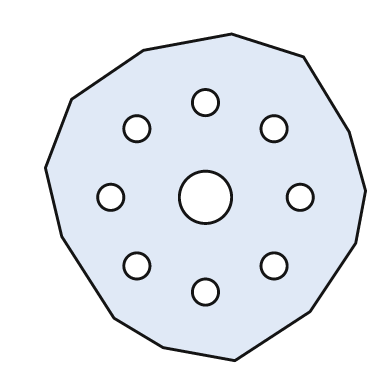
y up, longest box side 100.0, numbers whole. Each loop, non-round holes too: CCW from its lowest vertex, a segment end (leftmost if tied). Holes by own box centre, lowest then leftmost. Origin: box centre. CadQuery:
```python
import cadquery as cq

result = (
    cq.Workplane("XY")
    .moveTo(9.0, -50.0)
    .lineTo(32.0, -35.0)
    .lineTo(46.0, -14.0)
    .lineTo(49.0, 2.0)
    .lineTo(44.0, 20.0)
    .lineTo(30.0, 43.0)
    .lineTo(8.0, 50.0)
    .lineTo(-19.0, 45.0)
    .lineTo(-41.0, 30.0)
    .lineTo(-49.0, 9.0)
    .lineTo(-44.0, -12.0)
    .lineTo(-28.0, -37.0)
    .lineTo(-13.0, -46.0)
    .close()
    .moveTo(0.0, -29.0)
    .circle(4.0)
    .moveTo(-21.0, -21.0)
    .circle(4.0)
    .moveTo(21.0, -21.0)
    .circle(4.0)
    .moveTo(-29.0, 0.0)
    .circle(4.0)
    .moveTo(0.0, 0.0)
    .circle(8.0)
    .moveTo(29.0, 0.0)
    .circle(4.0)
    .moveTo(-21.0, 21.0)
    .circle(4.0)
    .moveTo(21.0, 21.0)
    .circle(4.0)
    .moveTo(0.0, 29.0)
    .circle(4.0)
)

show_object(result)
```